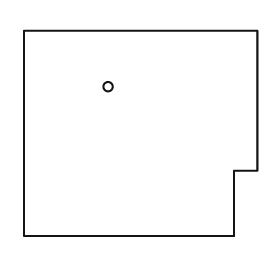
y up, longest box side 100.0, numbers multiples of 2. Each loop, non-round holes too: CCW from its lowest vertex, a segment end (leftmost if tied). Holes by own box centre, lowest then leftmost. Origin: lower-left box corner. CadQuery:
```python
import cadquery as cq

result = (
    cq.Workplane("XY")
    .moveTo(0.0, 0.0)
    .lineTo(90.0, 0.0)
    .lineTo(90.0, 28.0)
    .lineTo(100.0, 28.0)
    .lineTo(100.0, 88.0)
    .lineTo(0.0, 88.0)
    .close()
    .moveTo(36.0, 64.0)
    .circle(2.0)
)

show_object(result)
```